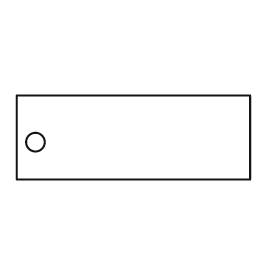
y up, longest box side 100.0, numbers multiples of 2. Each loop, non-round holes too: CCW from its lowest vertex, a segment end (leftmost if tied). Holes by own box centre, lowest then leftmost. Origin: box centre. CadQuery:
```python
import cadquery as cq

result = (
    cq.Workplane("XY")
    .moveTo(-50.0, -18.0)
    .lineTo(50.0, -18.0)
    .lineTo(50.0, 18.0)
    .lineTo(-50.0, 18.0)
    .close()
    .moveTo(-42.0, -2.0)
    .circle(4.0)
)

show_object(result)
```